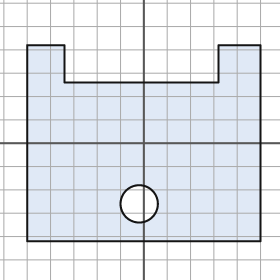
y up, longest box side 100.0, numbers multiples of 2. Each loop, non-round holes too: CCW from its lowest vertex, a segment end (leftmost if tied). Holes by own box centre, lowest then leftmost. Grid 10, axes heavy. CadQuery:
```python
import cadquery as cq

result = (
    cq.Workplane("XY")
    .moveTo(-50.0, -42.0)
    .lineTo(50.0, -42.0)
    .lineTo(50.0, 42.0)
    .lineTo(32.0, 42.0)
    .lineTo(32.0, 26.0)
    .lineTo(-34.0, 26.0)
    .lineTo(-34.0, 42.0)
    .lineTo(-50.0, 42.0)
    .close()
    .moveTo(-2.0, -26.0)
    .circle(8.0)
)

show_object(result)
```